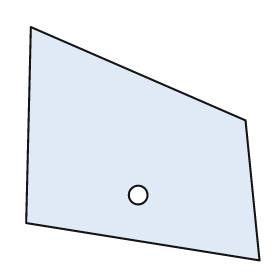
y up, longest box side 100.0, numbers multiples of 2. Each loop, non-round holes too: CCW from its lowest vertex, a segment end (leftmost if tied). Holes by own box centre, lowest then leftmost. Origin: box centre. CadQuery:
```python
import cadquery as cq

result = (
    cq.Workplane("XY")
    .moveTo(50.0, -50.0)
    .lineTo(44.0, 10.0)
    .lineTo(-48.0, 50.0)
    .lineTo(-50.0, -34.0)
    .close()
    .moveTo(-2.0, -22.0)
    .circle(4.0)
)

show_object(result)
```